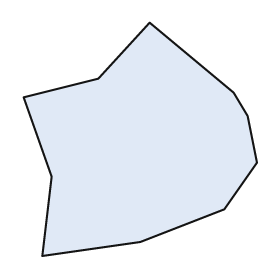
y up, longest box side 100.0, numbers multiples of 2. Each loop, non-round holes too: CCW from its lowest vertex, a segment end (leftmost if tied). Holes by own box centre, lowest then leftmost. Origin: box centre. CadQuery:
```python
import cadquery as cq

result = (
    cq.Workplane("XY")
    .moveTo(-42.0, -50.0)
    .lineTo(0.0, -44.0)
    .lineTo(36.0, -30.0)
    .lineTo(50.0, -10.0)
    .lineTo(46.0, 10.0)
    .lineTo(40.0, 20.0)
    .lineTo(4.0, 50.0)
    .lineTo(-18.0, 26.0)
    .lineTo(-50.0, 18.0)
    .lineTo(-38.0, -16.0)
    .close()
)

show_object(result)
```